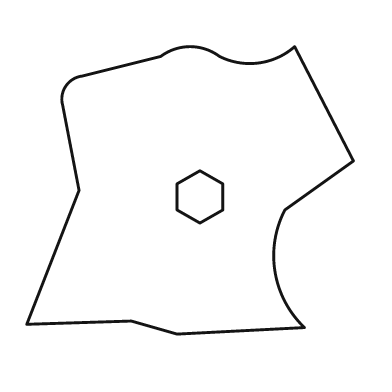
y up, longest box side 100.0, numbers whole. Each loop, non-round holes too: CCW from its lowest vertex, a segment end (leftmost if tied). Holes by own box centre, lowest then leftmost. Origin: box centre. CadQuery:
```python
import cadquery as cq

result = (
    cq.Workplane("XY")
    .moveTo(-4.0, -44.0)
    .lineTo(35.0, -42.0)
    .threePointArc((26.0, -25.0), (29.0, -6.0))
    .lineTo(50.0, 9.0)
    .lineTo(32.0, 44.0)
    .threePointArc((21.0, 39.0), (9.0, 41.0))
    .threePointArc((0.0, 44.0), (-9.0, 41.0))
    .lineTo(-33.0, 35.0)
    .threePointArc((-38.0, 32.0), (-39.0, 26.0))
    .lineTo(-34.0, 0.0)
    .lineTo(-50.0, -41.0)
    .lineTo(-18.0, -40.0)
    .close()
    .moveTo(3.0, -10.0)
    .lineTo(10.0, -6.0)
    .lineTo(10.0, 2.0)
    .lineTo(3.0, 6.0)
    .lineTo(-4.0, 2.0)
    .lineTo(-4.0, -6.0)
    .close()
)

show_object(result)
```